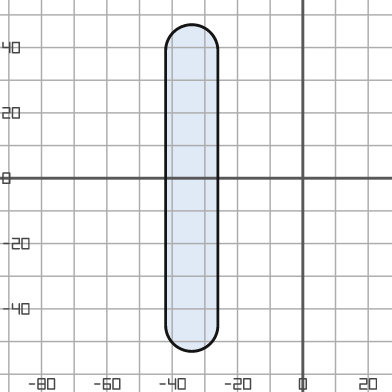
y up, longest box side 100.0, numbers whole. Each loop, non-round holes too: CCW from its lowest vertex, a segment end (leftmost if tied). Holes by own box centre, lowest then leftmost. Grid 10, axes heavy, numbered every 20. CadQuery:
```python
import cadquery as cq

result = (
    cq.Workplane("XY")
    .moveTo(-42.0, -45.0)
    .threePointArc((-34.0, -53.0), (-26.0, -45.0))
    .lineTo(-26.0, 39.0)
    .threePointArc((-34.0, 47.0), (-42.0, 39.0))
    .close()
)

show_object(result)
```